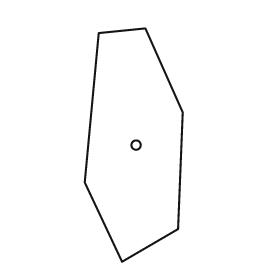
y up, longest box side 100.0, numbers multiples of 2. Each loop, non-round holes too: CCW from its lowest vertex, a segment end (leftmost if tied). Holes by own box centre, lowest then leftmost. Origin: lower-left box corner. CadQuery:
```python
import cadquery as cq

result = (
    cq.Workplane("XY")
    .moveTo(16.0, 0.0)
    .lineTo(40.0, 14.0)
    .lineTo(42.0, 64.0)
    .lineTo(26.0, 100.0)
    .lineTo(6.0, 98.0)
    .lineTo(0.0, 34.0)
    .close()
    .moveTo(22.0, 50.0)
    .circle(2.0)
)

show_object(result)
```